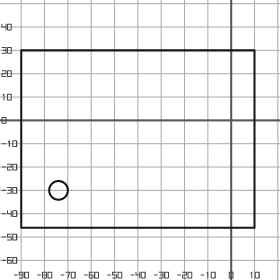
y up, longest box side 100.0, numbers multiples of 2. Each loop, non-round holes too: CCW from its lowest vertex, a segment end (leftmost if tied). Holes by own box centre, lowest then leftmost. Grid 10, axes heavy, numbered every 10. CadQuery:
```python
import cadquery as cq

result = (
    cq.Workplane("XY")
    .moveTo(-90.0, -46.0)
    .lineTo(10.0, -46.0)
    .lineTo(10.0, 30.0)
    .lineTo(-90.0, 30.0)
    .close()
    .moveTo(-74.0, -30.0)
    .circle(4.0)
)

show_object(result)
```